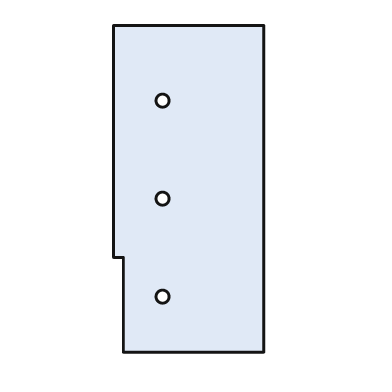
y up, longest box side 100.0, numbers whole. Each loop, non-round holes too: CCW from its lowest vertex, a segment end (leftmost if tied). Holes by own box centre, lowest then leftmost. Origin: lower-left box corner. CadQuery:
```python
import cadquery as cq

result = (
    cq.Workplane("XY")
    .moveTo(3.0, 0.0)
    .lineTo(46.0, 0.0)
    .lineTo(46.0, 100.0)
    .lineTo(0.0, 100.0)
    .lineTo(0.0, 29.0)
    .lineTo(3.0, 29.0)
    .close()
    .moveTo(15.0, 17.0)
    .circle(2.0)
    .moveTo(15.0, 47.0)
    .circle(2.0)
    .moveTo(15.0, 77.0)
    .circle(2.0)
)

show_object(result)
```